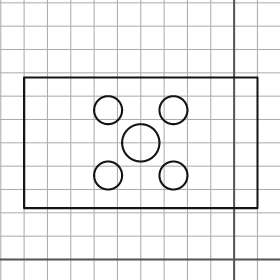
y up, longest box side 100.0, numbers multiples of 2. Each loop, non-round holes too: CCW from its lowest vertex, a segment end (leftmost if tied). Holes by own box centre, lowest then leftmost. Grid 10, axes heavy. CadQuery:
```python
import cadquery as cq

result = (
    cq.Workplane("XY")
    .moveTo(-90.0, 22.0)
    .lineTo(10.0, 22.0)
    .lineTo(10.0, 78.0)
    .lineTo(-90.0, 78.0)
    .close()
    .moveTo(-54.0, 36.0)
    .circle(6.0)
    .moveTo(-26.0, 36.0)
    .circle(6.0)
    .moveTo(-40.0, 50.0)
    .circle(8.0)
    .moveTo(-54.0, 64.0)
    .circle(6.0)
    .moveTo(-26.0, 64.0)
    .circle(6.0)
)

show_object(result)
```